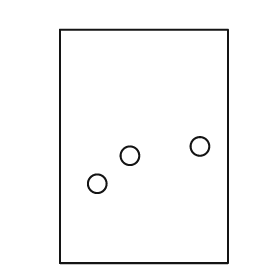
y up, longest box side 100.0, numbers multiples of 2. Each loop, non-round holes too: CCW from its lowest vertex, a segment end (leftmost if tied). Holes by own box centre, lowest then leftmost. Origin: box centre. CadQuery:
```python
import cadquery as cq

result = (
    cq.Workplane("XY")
    .moveTo(-36.0, -50.0)
    .lineTo(36.0, -50.0)
    .lineTo(36.0, 50.0)
    .lineTo(-36.0, 50.0)
    .close()
    .moveTo(-20.0, -16.0)
    .circle(4.0)
    .moveTo(-6.0, -4.0)
    .circle(4.0)
    .moveTo(24.0, 0.0)
    .circle(4.0)
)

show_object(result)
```